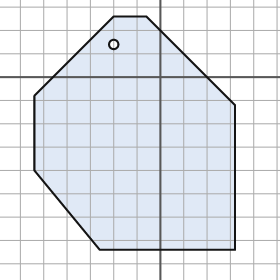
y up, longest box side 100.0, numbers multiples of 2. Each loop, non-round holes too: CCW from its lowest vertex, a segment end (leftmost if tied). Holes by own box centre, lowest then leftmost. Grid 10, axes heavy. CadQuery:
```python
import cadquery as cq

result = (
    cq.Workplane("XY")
    .moveTo(-26.0, -74.0)
    .lineTo(32.0, -74.0)
    .lineTo(32.0, -12.0)
    .lineTo(-6.0, 26.0)
    .lineTo(-20.0, 26.0)
    .lineTo(-54.0, -8.0)
    .lineTo(-54.0, -40.0)
    .close()
    .moveTo(-20.0, 14.0)
    .circle(2.0)
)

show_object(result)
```